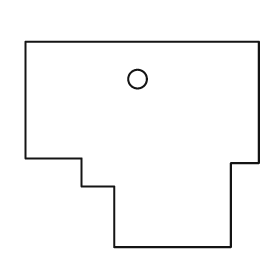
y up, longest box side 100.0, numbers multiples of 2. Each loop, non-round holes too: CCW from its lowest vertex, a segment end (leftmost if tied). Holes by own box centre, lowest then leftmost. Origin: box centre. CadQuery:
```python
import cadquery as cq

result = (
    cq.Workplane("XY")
    .moveTo(-12.0, -44.0)
    .lineTo(38.0, -44.0)
    .lineTo(38.0, -8.0)
    .lineTo(50.0, -8.0)
    .lineTo(50.0, 44.0)
    .lineTo(-50.0, 44.0)
    .lineTo(-50.0, -6.0)
    .lineTo(-26.0, -6.0)
    .lineTo(-26.0, -18.0)
    .lineTo(-12.0, -18.0)
    .close()
    .moveTo(-2.0, 28.0)
    .circle(4.0)
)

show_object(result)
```